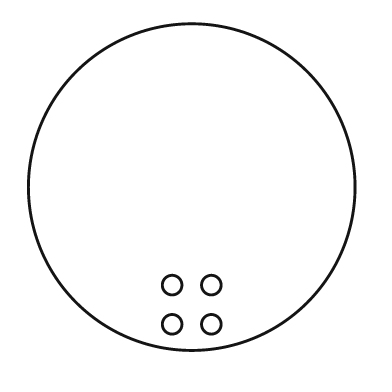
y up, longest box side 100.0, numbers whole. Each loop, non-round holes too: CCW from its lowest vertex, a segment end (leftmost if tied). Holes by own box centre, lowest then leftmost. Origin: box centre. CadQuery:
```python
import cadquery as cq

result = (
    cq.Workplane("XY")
    .moveTo(0.0, 0.0)
    .circle(50.0)
    .moveTo(-6.0, -42.0)
    .circle(3.0)
    .moveTo(6.0, -42.0)
    .circle(3.0)
    .moveTo(-6.0, -30.0)
    .circle(3.0)
    .moveTo(6.0, -30.0)
    .circle(3.0)
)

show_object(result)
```